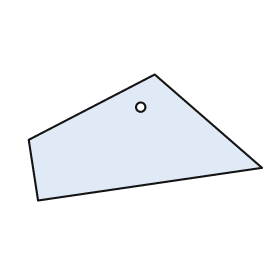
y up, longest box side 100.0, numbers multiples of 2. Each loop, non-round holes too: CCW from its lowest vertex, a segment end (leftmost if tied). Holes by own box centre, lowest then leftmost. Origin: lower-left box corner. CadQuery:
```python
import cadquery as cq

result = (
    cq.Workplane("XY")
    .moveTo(4.0, 0.0)
    .lineTo(100.0, 14.0)
    .lineTo(54.0, 54.0)
    .lineTo(0.0, 26.0)
    .close()
    .moveTo(48.0, 40.0)
    .circle(2.0)
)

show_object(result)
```